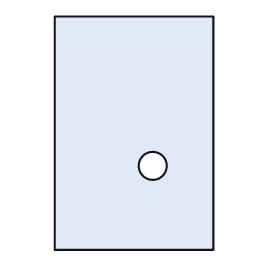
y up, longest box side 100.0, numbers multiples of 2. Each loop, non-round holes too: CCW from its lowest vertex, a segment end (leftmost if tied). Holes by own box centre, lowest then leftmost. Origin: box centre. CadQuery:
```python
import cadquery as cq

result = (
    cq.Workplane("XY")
    .moveTo(-34.0, -50.0)
    .lineTo(34.0, -50.0)
    .lineTo(34.0, 50.0)
    .lineTo(-34.0, 50.0)
    .close()
    .moveTo(8.0, -14.0)
    .circle(6.0)
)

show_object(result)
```